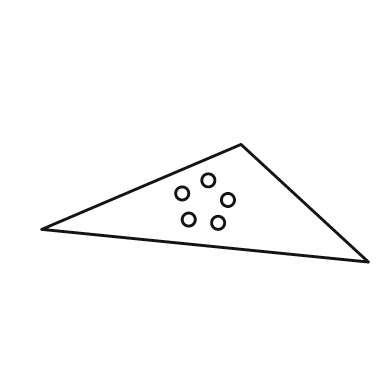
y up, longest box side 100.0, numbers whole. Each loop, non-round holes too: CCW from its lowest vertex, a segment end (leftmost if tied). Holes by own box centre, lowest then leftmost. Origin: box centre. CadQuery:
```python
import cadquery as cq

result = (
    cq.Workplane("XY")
    .moveTo(50.0, -18.0)
    .lineTo(11.0, 18.0)
    .lineTo(-50.0, -8.0)
    .close()
    .moveTo(4.0, -6.0)
    .circle(2.0)
    .moveTo(-5.0, -5.0)
    .circle(2.0)
    .moveTo(7.0, 1.0)
    .circle(2.0)
    .moveTo(-7.0, 3.0)
    .circle(2.0)
    .moveTo(1.0, 7.0)
    .circle(2.0)
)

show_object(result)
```